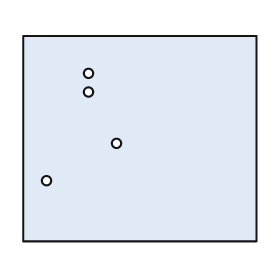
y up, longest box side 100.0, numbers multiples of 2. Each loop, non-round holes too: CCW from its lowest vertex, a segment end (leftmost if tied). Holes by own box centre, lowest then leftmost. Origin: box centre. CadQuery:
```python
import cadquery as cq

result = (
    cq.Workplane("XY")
    .moveTo(-50.0, -44.0)
    .lineTo(50.0, -44.0)
    .lineTo(50.0, 44.0)
    .lineTo(-50.0, 44.0)
    .close()
    .moveTo(-40.0, -18.0)
    .circle(2.0)
    .moveTo(-10.0, -2.0)
    .circle(2.0)
    .moveTo(-22.0, 20.0)
    .circle(2.0)
    .moveTo(-22.0, 28.0)
    .circle(2.0)
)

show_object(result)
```